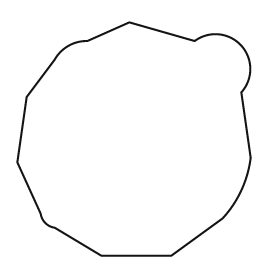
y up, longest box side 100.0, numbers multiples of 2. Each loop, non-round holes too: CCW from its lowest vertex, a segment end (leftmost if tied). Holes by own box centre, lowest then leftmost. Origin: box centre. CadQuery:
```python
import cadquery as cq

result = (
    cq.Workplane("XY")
    .moveTo(-14.0, -50.0)
    .lineTo(16.0, -50.0)
    .lineTo(38.0, -34.0)
    .threePointArc((46.0, -22.0), (50.0, -8.0))
    .lineTo(46.0, 20.0)
    .threePointArc((46.0, 40.0), (26.0, 42.0))
    .lineTo(-2.0, 50.0)
    .lineTo(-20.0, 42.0)
    .threePointArc((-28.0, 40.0), (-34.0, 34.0))
    .lineTo(-46.0, 18.0)
    .lineTo(-50.0, -10.0)
    .lineTo(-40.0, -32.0)
    .threePointArc((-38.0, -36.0), (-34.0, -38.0))
    .close()
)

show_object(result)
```